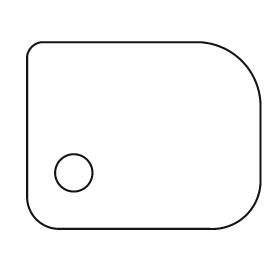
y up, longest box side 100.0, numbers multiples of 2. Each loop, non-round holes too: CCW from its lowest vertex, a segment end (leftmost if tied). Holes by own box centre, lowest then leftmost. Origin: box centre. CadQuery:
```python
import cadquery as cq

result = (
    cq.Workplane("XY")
    .moveTo(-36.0, -40.0)
    .lineTo(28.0, -40.0)
    .threePointArc((44.0, -34.0), (50.0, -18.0))
    .lineTo(50.0, 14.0)
    .threePointArc((42.0, 32.0), (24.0, 40.0))
    .lineTo(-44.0, 40.0)
    .threePointArc((-48.0, 38.0), (-50.0, 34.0))
    .lineTo(-50.0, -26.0)
    .threePointArc((-46.0, -36.0), (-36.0, -40.0))
    .close()
    .moveTo(-30.0, -16.0)
    .circle(8.0)
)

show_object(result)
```